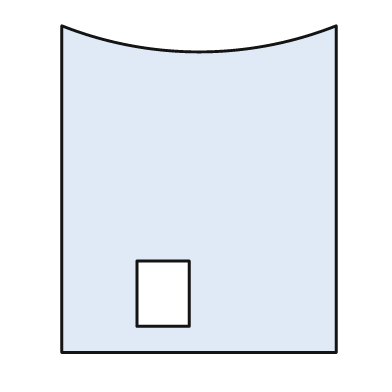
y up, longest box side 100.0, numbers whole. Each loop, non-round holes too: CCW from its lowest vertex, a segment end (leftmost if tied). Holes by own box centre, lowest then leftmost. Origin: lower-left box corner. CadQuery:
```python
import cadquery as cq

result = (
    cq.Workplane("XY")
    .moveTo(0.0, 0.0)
    .lineTo(84.0, 0.0)
    .lineTo(84.0, 100.0)
    .threePointArc((42.0, 92.0), (0.0, 100.0))
    .close()
    .moveTo(23.0, 8.0)
    .lineTo(39.0, 8.0)
    .lineTo(39.0, 28.0)
    .lineTo(23.0, 28.0)
    .close()
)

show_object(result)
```